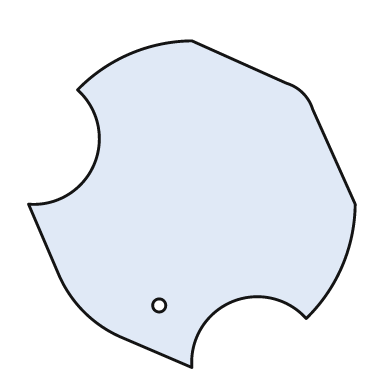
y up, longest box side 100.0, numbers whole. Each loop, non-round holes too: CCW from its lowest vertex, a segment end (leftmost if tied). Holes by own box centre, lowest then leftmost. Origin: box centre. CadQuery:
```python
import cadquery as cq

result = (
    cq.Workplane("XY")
    .moveTo(0.0, -50.0)
    .threePointArc((12.0, -30.0), (35.0, -35.0))
    .threePointArc((46.0, -19.0), (50.0, 0.0))
    .lineTo(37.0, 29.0)
    .threePointArc((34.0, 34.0), (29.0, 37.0))
    .lineTo(0.0, 50.0)
    .threePointArc((-19.0, 46.0), (-35.0, 35.0))
    .threePointArc((-30.0, 12.0), (-50.0, 0.0))
    .lineTo(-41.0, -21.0)
    .threePointArc((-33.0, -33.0), (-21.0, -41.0))
    .close()
    .moveTo(-10.0, -31.0)
    .circle(2.0)
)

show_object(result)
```